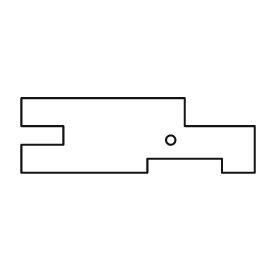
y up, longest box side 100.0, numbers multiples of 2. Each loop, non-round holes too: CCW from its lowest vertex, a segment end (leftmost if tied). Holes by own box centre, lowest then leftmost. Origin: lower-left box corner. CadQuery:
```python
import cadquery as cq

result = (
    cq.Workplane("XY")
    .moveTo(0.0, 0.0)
    .lineTo(54.0, 0.0)
    .lineTo(54.0, 6.0)
    .lineTo(86.0, 6.0)
    .lineTo(86.0, 0.0)
    .lineTo(100.0, 0.0)
    .lineTo(100.0, 20.0)
    .lineTo(70.0, 20.0)
    .lineTo(70.0, 32.0)
    .lineTo(0.0, 32.0)
    .lineTo(0.0, 20.0)
    .lineTo(18.0, 20.0)
    .lineTo(18.0, 12.0)
    .lineTo(0.0, 12.0)
    .close()
    .moveTo(64.0, 14.0)
    .circle(2.0)
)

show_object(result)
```